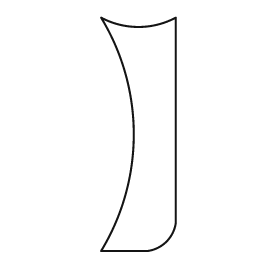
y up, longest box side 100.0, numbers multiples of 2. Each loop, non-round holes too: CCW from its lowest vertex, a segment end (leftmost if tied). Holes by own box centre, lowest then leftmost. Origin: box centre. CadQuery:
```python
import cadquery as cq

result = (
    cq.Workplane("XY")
    .moveTo(-16.0, -50.0)
    .lineTo(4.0, -50.0)
    .threePointArc((12.0, -46.0), (16.0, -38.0))
    .lineTo(16.0, 50.0)
    .threePointArc((0.0, 46.0), (-16.0, 50.0))
    .threePointArc((-2.0, 0.0), (-16.0, -50.0))
    .close()
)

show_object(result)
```